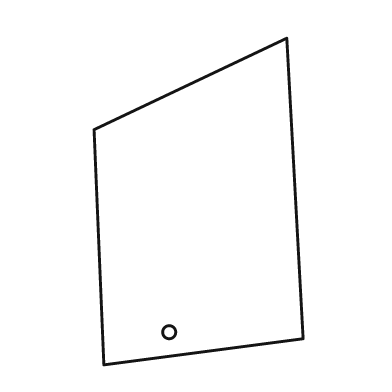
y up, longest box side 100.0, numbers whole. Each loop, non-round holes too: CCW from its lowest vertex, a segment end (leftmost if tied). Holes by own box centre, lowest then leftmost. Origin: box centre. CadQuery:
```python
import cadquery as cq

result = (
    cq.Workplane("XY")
    .moveTo(-29.0, -50.0)
    .lineTo(32.0, -42.0)
    .lineTo(27.0, 50.0)
    .lineTo(-32.0, 22.0)
    .close()
    .moveTo(-9.0, -40.0)
    .circle(2.0)
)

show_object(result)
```